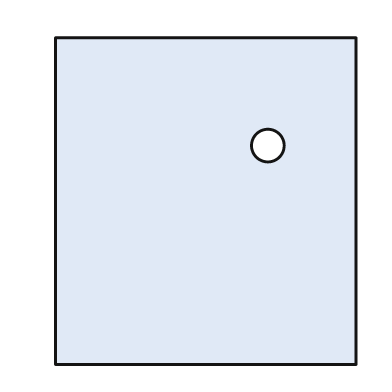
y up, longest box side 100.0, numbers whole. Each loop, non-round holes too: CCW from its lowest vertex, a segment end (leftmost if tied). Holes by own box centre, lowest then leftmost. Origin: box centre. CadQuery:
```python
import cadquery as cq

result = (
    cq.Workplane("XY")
    .moveTo(-46.0, -50.0)
    .lineTo(46.0, -50.0)
    .lineTo(46.0, 50.0)
    .lineTo(-46.0, 50.0)
    .close()
    .moveTo(19.0, 17.0)
    .circle(5.0)
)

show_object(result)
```